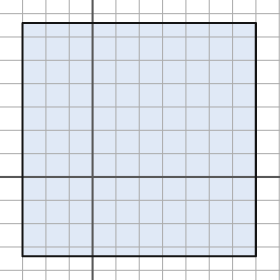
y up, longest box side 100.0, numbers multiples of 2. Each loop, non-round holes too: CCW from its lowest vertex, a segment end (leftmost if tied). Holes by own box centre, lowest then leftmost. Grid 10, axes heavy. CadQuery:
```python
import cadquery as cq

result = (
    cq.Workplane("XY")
    .moveTo(-30.0, -34.0)
    .lineTo(70.0, -34.0)
    .lineTo(70.0, 66.0)
    .lineTo(-30.0, 66.0)
    .close()
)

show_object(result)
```